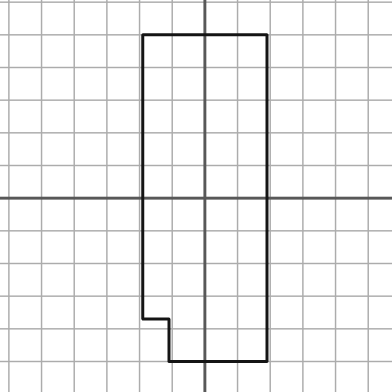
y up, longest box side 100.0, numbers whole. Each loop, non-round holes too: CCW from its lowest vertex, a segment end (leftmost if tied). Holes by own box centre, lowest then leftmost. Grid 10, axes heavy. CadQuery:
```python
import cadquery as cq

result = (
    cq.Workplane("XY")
    .moveTo(-11.0, -50.0)
    .lineTo(19.0, -50.0)
    .lineTo(19.0, 50.0)
    .lineTo(-19.0, 50.0)
    .lineTo(-19.0, -37.0)
    .lineTo(-11.0, -37.0)
    .close()
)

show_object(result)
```